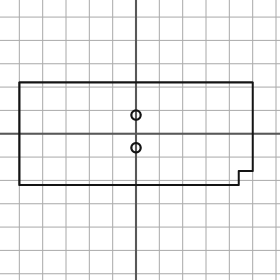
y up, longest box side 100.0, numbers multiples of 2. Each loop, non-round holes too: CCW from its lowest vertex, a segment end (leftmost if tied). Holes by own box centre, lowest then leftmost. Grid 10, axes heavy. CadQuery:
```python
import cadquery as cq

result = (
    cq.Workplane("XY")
    .moveTo(-50.0, -22.0)
    .lineTo(44.0, -22.0)
    .lineTo(44.0, -16.0)
    .lineTo(50.0, -16.0)
    .lineTo(50.0, 22.0)
    .lineTo(-50.0, 22.0)
    .close()
    .moveTo(0.0, -6.0)
    .circle(2.0)
    .moveTo(0.0, 8.0)
    .circle(2.0)
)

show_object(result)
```